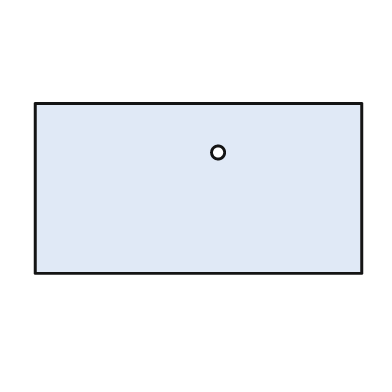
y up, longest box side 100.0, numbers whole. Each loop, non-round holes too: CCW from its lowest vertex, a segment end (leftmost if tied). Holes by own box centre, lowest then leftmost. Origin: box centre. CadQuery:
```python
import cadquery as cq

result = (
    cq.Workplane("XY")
    .moveTo(-50.0, -26.0)
    .lineTo(50.0, -26.0)
    .lineTo(50.0, 26.0)
    .lineTo(-50.0, 26.0)
    .close()
    .moveTo(6.0, 11.0)
    .circle(2.0)
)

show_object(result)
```